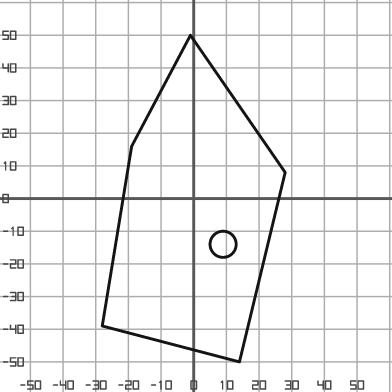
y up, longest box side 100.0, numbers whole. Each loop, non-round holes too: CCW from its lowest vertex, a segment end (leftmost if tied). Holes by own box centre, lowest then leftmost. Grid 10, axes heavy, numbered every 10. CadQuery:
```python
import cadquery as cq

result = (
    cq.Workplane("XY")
    .moveTo(14.0, -50.0)
    .lineTo(28.0, 8.0)
    .lineTo(-1.0, 50.0)
    .lineTo(-19.0, 16.0)
    .lineTo(-28.0, -39.0)
    .close()
    .moveTo(9.0, -14.0)
    .circle(4.0)
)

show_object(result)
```